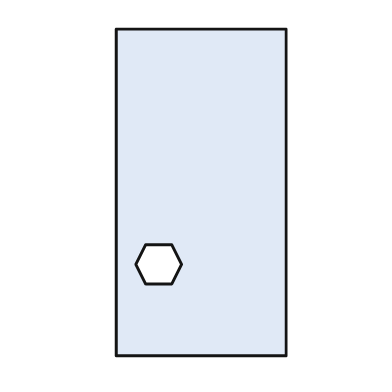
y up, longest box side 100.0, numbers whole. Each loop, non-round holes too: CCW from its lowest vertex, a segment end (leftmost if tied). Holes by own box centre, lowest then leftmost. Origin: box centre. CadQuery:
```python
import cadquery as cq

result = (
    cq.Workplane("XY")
    .moveTo(-26.0, -50.0)
    .lineTo(26.0, -50.0)
    .lineTo(26.0, 50.0)
    .lineTo(-26.0, 50.0)
    .close()
    .moveTo(-17.0, -28.0)
    .lineTo(-9.0, -28.0)
    .lineTo(-6.0, -22.0)
    .lineTo(-9.0, -16.0)
    .lineTo(-17.0, -16.0)
    .lineTo(-20.0, -22.0)
    .close()
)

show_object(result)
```